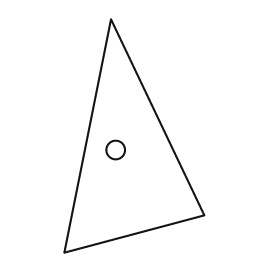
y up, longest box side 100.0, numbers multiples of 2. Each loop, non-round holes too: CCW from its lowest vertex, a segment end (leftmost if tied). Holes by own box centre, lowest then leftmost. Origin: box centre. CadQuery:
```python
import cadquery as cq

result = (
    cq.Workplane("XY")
    .moveTo(-30.0, -50.0)
    .lineTo(30.0, -34.0)
    .lineTo(-10.0, 50.0)
    .close()
    .moveTo(-8.0, -6.0)
    .circle(4.0)
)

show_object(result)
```